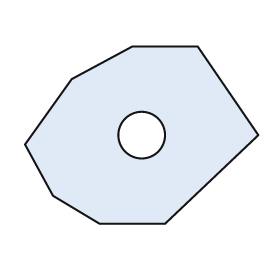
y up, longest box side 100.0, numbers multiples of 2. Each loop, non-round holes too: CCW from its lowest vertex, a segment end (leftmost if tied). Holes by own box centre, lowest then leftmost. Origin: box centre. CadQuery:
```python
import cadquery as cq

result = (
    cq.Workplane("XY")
    .moveTo(-18.0, -38.0)
    .lineTo(10.0, -38.0)
    .lineTo(50.0, 0.0)
    .lineTo(24.0, 38.0)
    .lineTo(-4.0, 38.0)
    .lineTo(-30.0, 24.0)
    .lineTo(-50.0, -4.0)
    .lineTo(-38.0, -26.0)
    .close()
    .moveTo(0.0, 0.0)
    .circle(10.0)
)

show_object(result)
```